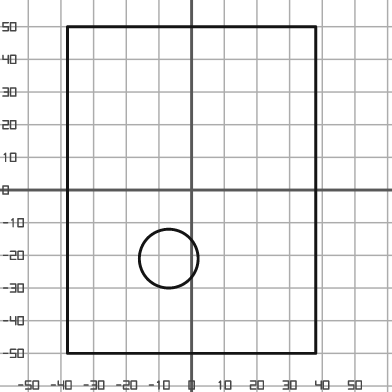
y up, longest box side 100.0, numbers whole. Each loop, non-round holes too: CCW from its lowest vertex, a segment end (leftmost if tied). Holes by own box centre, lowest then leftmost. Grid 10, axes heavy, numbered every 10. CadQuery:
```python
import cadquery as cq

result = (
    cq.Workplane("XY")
    .moveTo(-38.0, -50.0)
    .lineTo(38.0, -50.0)
    .lineTo(38.0, 50.0)
    .lineTo(-38.0, 50.0)
    .close()
    .moveTo(-7.0, -21.0)
    .circle(9.0)
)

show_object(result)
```